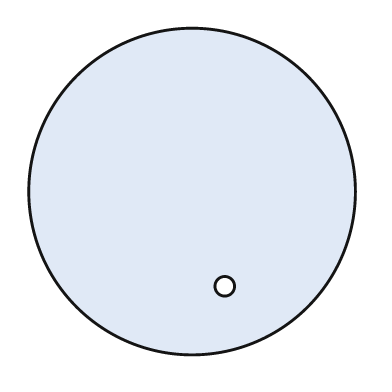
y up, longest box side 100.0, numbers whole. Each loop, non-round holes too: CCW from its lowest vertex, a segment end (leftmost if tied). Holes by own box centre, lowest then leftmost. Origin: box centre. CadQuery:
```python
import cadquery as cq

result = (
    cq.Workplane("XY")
    .moveTo(0.0, 0.0)
    .circle(50.0)
    .moveTo(10.0, -29.0)
    .circle(3.0)
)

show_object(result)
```